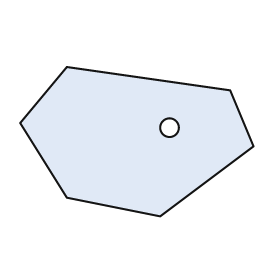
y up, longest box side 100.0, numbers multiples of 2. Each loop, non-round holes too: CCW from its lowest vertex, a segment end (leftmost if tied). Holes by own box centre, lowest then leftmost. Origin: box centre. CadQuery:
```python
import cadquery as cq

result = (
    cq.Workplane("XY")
    .moveTo(10.0, -32.0)
    .lineTo(50.0, -2.0)
    .lineTo(40.0, 22.0)
    .lineTo(-30.0, 32.0)
    .lineTo(-50.0, 8.0)
    .lineTo(-30.0, -24.0)
    .close()
    .moveTo(14.0, 6.0)
    .circle(4.0)
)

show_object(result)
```